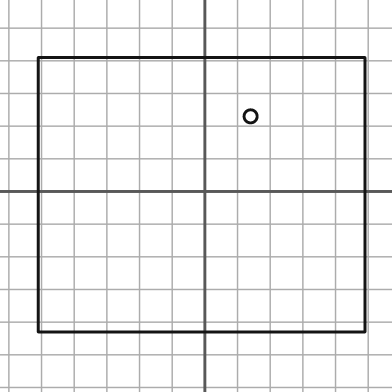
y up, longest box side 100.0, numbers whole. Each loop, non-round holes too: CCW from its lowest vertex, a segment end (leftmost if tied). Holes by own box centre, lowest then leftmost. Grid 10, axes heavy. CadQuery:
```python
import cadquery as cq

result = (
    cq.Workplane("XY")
    .moveTo(-51.0, -43.0)
    .lineTo(49.0, -43.0)
    .lineTo(49.0, 41.0)
    .lineTo(-51.0, 41.0)
    .close()
    .moveTo(14.0, 23.0)
    .circle(2.0)
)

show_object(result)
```